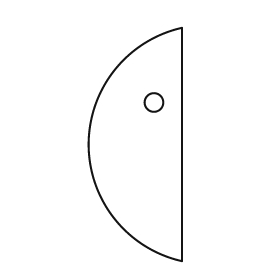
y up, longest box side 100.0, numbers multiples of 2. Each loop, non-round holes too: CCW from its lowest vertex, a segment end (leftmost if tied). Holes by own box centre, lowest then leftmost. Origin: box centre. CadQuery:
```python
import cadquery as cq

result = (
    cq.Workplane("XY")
    .moveTo(20.0, -50.0)
    .lineTo(20.0, 50.0)
    .threePointArc((-20.0, 0.0), (20.0, -50.0))
    .close()
    .moveTo(8.0, 18.0)
    .circle(4.0)
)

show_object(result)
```